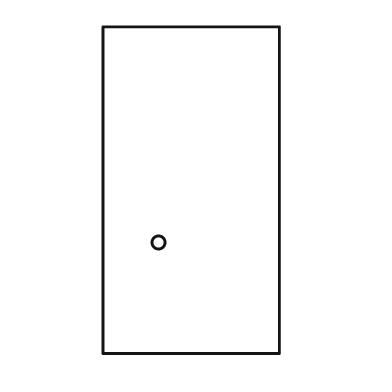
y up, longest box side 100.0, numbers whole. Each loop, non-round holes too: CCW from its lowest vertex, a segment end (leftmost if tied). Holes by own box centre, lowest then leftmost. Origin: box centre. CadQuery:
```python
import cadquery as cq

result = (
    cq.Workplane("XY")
    .moveTo(-27.0, -50.0)
    .lineTo(27.0, -50.0)
    .lineTo(27.0, 50.0)
    .lineTo(-27.0, 50.0)
    .close()
    .moveTo(-10.0, -16.0)
    .circle(2.0)
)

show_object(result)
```